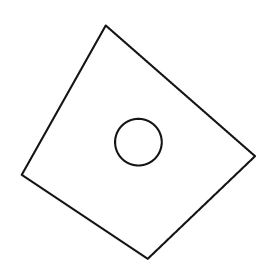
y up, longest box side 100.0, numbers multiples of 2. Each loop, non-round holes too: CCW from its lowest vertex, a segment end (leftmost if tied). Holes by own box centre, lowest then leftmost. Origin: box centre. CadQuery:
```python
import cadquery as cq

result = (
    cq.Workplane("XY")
    .moveTo(4.0, -50.0)
    .lineTo(50.0, -6.0)
    .lineTo(-14.0, 50.0)
    .lineTo(-50.0, -14.0)
    .close()
    .moveTo(0.0, 0.0)
    .circle(10.0)
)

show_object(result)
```